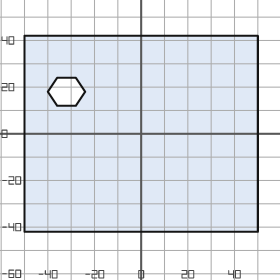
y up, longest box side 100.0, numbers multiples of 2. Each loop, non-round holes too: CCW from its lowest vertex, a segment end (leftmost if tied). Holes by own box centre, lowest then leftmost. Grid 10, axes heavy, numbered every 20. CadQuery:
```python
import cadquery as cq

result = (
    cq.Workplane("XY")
    .moveTo(-50.0, -42.0)
    .lineTo(50.0, -42.0)
    .lineTo(50.0, 42.0)
    .lineTo(-50.0, 42.0)
    .close()
    .moveTo(-36.0, 12.0)
    .lineTo(-28.0, 12.0)
    .lineTo(-24.0, 18.0)
    .lineTo(-28.0, 24.0)
    .lineTo(-36.0, 24.0)
    .lineTo(-40.0, 18.0)
    .close()
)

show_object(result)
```